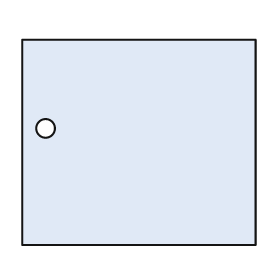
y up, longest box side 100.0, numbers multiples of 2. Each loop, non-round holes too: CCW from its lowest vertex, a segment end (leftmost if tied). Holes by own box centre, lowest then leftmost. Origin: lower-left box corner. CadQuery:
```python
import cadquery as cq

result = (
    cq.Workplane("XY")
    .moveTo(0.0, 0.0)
    .lineTo(100.0, 0.0)
    .lineTo(100.0, 88.0)
    .lineTo(0.0, 88.0)
    .close()
    .moveTo(10.0, 50.0)
    .circle(4.0)
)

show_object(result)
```